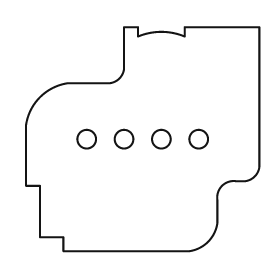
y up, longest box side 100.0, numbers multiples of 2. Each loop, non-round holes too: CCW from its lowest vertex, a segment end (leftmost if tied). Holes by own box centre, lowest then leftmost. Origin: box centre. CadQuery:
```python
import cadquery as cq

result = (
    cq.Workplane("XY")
    .moveTo(-34.0, -48.0)
    .lineTo(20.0, -48.0)
    .threePointArc((28.0, -44.0), (32.0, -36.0))
    .lineTo(32.0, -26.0)
    .threePointArc((34.0, -20.0), (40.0, -18.0))
    .lineTo(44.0, -18.0)
    .threePointArc((48.0, -16.0), (50.0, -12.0))
    .lineTo(50.0, 48.0)
    .lineTo(18.0, 48.0)
    .lineTo(18.0, 44.0)
    .threePointArc((8.0, 46.0), (-2.0, 44.0))
    .lineTo(-2.0, 48.0)
    .lineTo(-8.0, 48.0)
    .lineTo(-8.0, 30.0)
    .threePointArc((-10.0, 26.0), (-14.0, 24.0))
    .lineTo(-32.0, 24.0)
    .threePointArc((-44.0, 18.0), (-50.0, 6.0))
    .lineTo(-50.0, -20.0)
    .lineTo(-44.0, -20.0)
    .lineTo(-44.0, -42.0)
    .lineTo(-34.0, -42.0)
    .close()
    .moveTo(-24.0, 0.0)
    .circle(4.0)
    .moveTo(-8.0, 0.0)
    .circle(4.0)
    .moveTo(8.0, 0.0)
    .circle(4.0)
    .moveTo(24.0, 0.0)
    .circle(4.0)
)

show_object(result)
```